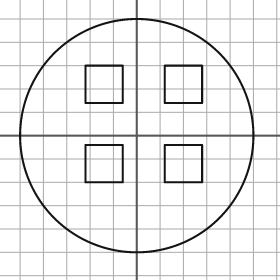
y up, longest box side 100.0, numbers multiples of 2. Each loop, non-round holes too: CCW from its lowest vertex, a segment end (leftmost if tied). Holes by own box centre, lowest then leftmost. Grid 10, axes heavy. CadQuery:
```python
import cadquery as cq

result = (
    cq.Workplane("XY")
    .moveTo(0.0, 0.0)
    .circle(50.0)
    .moveTo(-22.0, -20.0)
    .lineTo(-6.0, -20.0)
    .lineTo(-6.0, -4.0)
    .lineTo(-22.0, -4.0)
    .close()
    .moveTo(12.0, -20.0)
    .lineTo(28.0, -20.0)
    .lineTo(28.0, -4.0)
    .lineTo(12.0, -4.0)
    .close()
    .moveTo(-22.0, 14.0)
    .lineTo(-6.0, 14.0)
    .lineTo(-6.0, 30.0)
    .lineTo(-22.0, 30.0)
    .close()
    .moveTo(12.0, 14.0)
    .lineTo(28.0, 14.0)
    .lineTo(28.0, 30.0)
    .lineTo(12.0, 30.0)
    .close()
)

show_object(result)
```